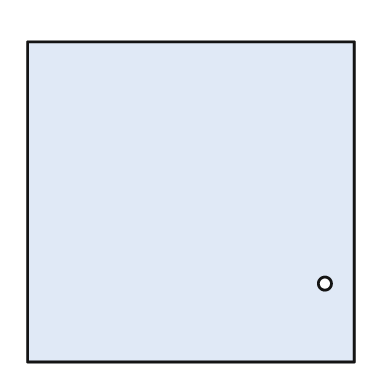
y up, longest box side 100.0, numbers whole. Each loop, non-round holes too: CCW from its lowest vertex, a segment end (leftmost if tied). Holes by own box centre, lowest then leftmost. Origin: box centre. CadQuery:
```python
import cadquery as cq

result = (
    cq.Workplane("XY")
    .moveTo(-50.0, -49.0)
    .lineTo(50.0, -49.0)
    .lineTo(50.0, 49.0)
    .lineTo(-50.0, 49.0)
    .close()
    .moveTo(41.0, -25.0)
    .circle(2.0)
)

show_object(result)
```